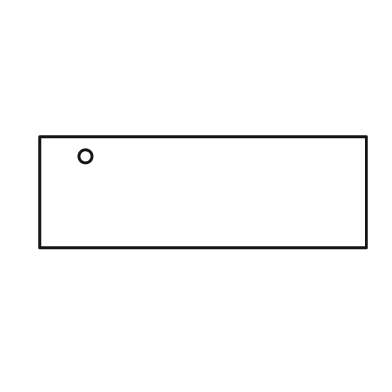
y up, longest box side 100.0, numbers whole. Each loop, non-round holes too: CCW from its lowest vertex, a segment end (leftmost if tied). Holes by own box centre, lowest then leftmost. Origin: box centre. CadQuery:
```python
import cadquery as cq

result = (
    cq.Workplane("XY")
    .moveTo(-50.0, -17.0)
    .lineTo(50.0, -17.0)
    .lineTo(50.0, 17.0)
    .lineTo(-50.0, 17.0)
    .close()
    .moveTo(-36.0, 11.0)
    .circle(2.0)
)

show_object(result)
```